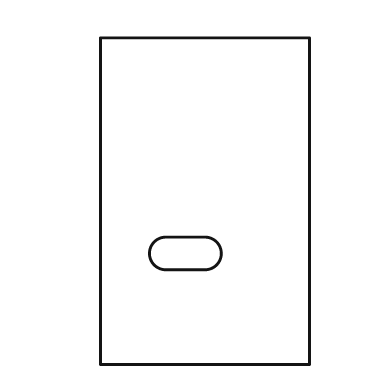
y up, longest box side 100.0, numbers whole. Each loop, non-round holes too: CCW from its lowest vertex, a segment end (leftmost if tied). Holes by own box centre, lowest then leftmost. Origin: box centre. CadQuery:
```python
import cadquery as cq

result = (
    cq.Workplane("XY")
    .moveTo(-32.0, -50.0)
    .lineTo(32.0, -50.0)
    .lineTo(32.0, 50.0)
    .lineTo(-32.0, 50.0)
    .close()
    .moveTo(-12.0, -21.0)
    .lineTo(0.0, -21.0)
    .threePointArc((5.0, -16.0), (0.0, -11.0))
    .lineTo(-12.0, -11.0)
    .threePointArc((-17.0, -16.0), (-12.0, -21.0))
    .close()
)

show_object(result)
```